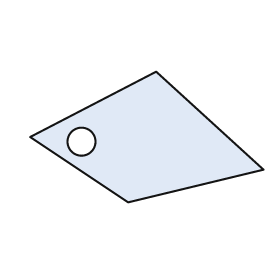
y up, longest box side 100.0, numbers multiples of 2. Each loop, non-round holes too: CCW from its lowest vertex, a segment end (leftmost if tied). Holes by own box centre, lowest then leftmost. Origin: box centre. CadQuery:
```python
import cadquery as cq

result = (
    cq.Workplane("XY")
    .moveTo(-8.0, -28.0)
    .lineTo(50.0, -14.0)
    .lineTo(4.0, 28.0)
    .lineTo(-50.0, 0.0)
    .close()
    .moveTo(-28.0, -2.0)
    .circle(6.0)
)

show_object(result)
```